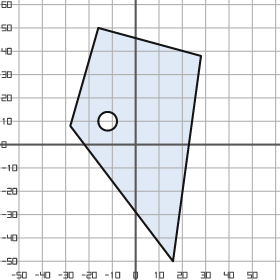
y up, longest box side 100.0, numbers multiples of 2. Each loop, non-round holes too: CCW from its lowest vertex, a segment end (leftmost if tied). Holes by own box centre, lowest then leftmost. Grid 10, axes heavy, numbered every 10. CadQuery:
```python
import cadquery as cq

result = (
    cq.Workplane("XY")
    .moveTo(16.0, -50.0)
    .lineTo(28.0, 38.0)
    .lineTo(-16.0, 50.0)
    .lineTo(-28.0, 8.0)
    .close()
    .moveTo(-12.0, 10.0)
    .circle(4.0)
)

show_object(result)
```